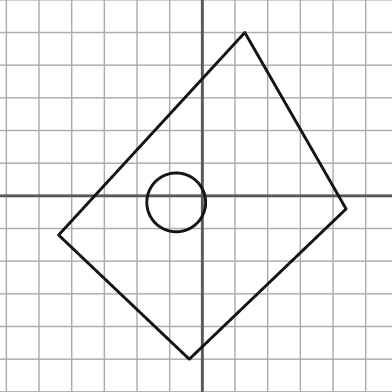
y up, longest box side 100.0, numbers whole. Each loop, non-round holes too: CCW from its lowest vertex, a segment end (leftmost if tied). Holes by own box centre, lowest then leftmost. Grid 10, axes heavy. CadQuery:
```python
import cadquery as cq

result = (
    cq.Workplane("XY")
    .moveTo(-4.0, -50.0)
    .lineTo(44.0, -4.0)
    .lineTo(13.0, 50.0)
    .lineTo(-44.0, -12.0)
    .close()
    .moveTo(-8.0, -2.0)
    .circle(9.0)
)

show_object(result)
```